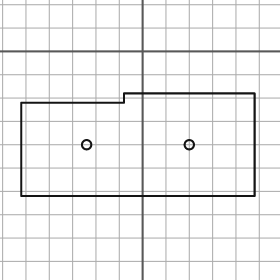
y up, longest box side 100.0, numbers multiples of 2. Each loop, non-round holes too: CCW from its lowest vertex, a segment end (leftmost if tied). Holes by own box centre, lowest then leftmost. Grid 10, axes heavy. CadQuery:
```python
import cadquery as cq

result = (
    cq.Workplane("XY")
    .moveTo(-52.0, -62.0)
    .lineTo(48.0, -62.0)
    .lineTo(48.0, -18.0)
    .lineTo(-8.0, -18.0)
    .lineTo(-8.0, -22.0)
    .lineTo(-52.0, -22.0)
    .close()
    .moveTo(-24.0, -40.0)
    .circle(2.0)
    .moveTo(20.0, -40.0)
    .circle(2.0)
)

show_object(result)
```